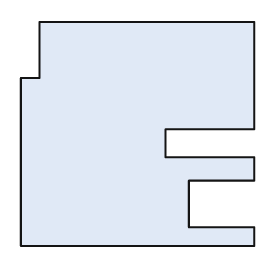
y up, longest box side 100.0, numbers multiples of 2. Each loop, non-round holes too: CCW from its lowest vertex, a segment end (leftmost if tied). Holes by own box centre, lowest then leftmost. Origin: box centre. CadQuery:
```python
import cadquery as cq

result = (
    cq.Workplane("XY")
    .moveTo(-50.0, -48.0)
    .lineTo(50.0, -48.0)
    .lineTo(50.0, -40.0)
    .lineTo(22.0, -40.0)
    .lineTo(22.0, -20.0)
    .lineTo(50.0, -20.0)
    .lineTo(50.0, -10.0)
    .lineTo(12.0, -10.0)
    .lineTo(12.0, 2.0)
    .lineTo(50.0, 2.0)
    .lineTo(50.0, 48.0)
    .lineTo(-42.0, 48.0)
    .lineTo(-42.0, 24.0)
    .lineTo(-50.0, 24.0)
    .close()
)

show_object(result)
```